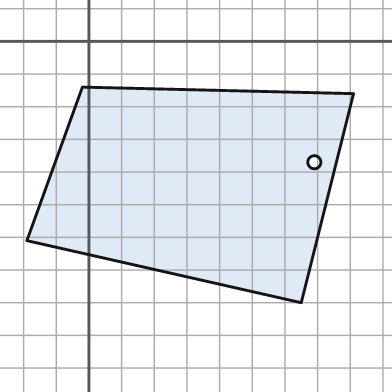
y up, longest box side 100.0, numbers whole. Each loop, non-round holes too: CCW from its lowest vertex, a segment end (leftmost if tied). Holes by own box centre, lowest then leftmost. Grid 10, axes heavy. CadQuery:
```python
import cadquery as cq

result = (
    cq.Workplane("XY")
    .moveTo(65.0, -80.0)
    .lineTo(81.0, -16.0)
    .lineTo(-2.0, -14.0)
    .lineTo(-19.0, -61.0)
    .close()
    .moveTo(69.0, -37.0)
    .circle(2.0)
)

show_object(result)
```